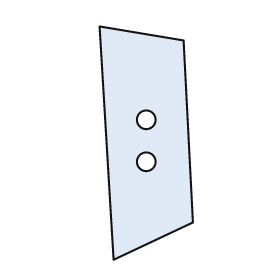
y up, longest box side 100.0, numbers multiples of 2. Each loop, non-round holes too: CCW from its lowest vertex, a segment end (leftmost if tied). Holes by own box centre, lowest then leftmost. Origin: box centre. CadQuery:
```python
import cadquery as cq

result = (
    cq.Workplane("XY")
    .moveTo(-14.0, -50.0)
    .lineTo(20.0, -34.0)
    .lineTo(16.0, 44.0)
    .lineTo(-20.0, 50.0)
    .close()
    .moveTo(0.0, -8.0)
    .circle(4.0)
    .moveTo(0.0, 10.0)
    .circle(4.0)
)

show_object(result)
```